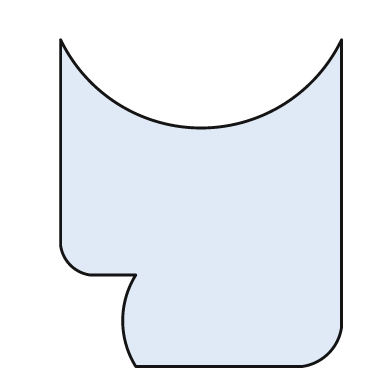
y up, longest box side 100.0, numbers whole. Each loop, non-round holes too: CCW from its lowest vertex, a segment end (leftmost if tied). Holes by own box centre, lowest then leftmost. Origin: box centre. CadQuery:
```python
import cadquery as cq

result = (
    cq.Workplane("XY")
    .moveTo(-20.0, -50.0)
    .lineTo(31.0, -50.0)
    .threePointArc((39.0, -46.0), (43.0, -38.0))
    .lineTo(43.0, 50.0)
    .threePointArc((0.0, 23.0), (-43.0, 50.0))
    .lineTo(-43.0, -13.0)
    .threePointArc((-40.0, -19.0), (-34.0, -22.0))
    .lineTo(-20.0, -22.0)
    .threePointArc((-24.0, -36.0), (-20.0, -50.0))
    .close()
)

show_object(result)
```